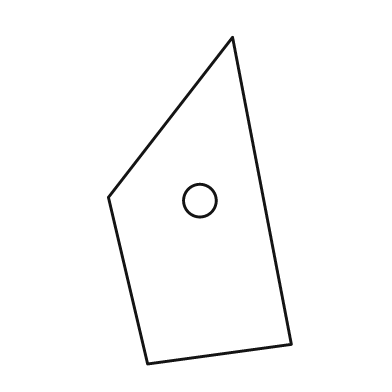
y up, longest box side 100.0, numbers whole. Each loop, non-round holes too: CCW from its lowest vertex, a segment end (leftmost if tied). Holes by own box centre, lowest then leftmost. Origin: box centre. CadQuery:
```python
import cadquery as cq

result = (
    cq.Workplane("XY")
    .moveTo(-16.0, -50.0)
    .lineTo(28.0, -44.0)
    .lineTo(10.0, 50.0)
    .lineTo(-28.0, 1.0)
    .close()
    .moveTo(0.0, 0.0)
    .circle(5.0)
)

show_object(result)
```